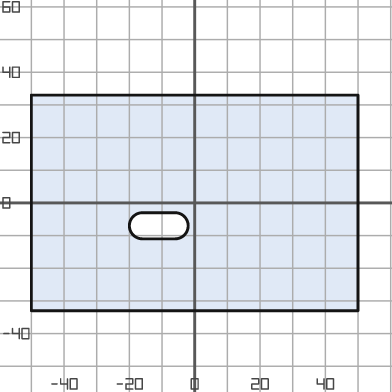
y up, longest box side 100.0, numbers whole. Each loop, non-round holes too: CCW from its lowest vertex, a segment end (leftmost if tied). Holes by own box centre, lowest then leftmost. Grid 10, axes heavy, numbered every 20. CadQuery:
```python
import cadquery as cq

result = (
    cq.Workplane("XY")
    .moveTo(-50.0, -33.0)
    .lineTo(50.0, -33.0)
    .lineTo(50.0, 33.0)
    .lineTo(-50.0, 33.0)
    .close()
    .moveTo(-16.0, -11.0)
    .lineTo(-6.0, -11.0)
    .threePointArc((-2.0, -7.0), (-6.0, -3.0))
    .lineTo(-16.0, -3.0)
    .threePointArc((-20.0, -7.0), (-16.0, -11.0))
    .close()
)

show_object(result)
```